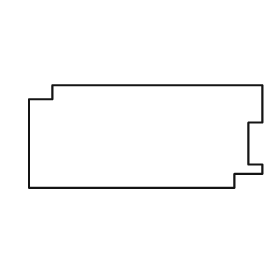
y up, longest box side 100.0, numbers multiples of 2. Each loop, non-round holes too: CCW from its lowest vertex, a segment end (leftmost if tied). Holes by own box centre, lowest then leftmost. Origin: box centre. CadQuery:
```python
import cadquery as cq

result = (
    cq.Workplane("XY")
    .moveTo(-50.0, -22.0)
    .lineTo(38.0, -22.0)
    .lineTo(38.0, -16.0)
    .lineTo(50.0, -16.0)
    .lineTo(50.0, -12.0)
    .lineTo(44.0, -12.0)
    .lineTo(44.0, 6.0)
    .lineTo(50.0, 6.0)
    .lineTo(50.0, 22.0)
    .lineTo(-40.0, 22.0)
    .lineTo(-40.0, 16.0)
    .lineTo(-50.0, 16.0)
    .close()
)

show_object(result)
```